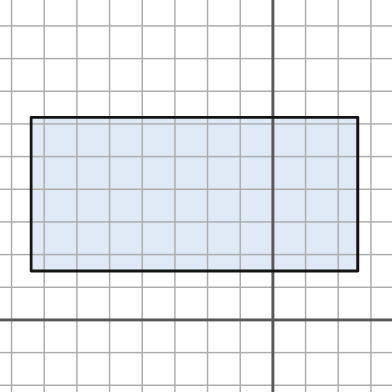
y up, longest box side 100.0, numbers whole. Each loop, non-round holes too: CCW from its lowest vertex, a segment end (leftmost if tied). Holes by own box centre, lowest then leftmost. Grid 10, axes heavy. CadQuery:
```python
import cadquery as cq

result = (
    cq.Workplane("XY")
    .moveTo(-74.0, 15.0)
    .lineTo(26.0, 15.0)
    .lineTo(26.0, 62.0)
    .lineTo(-74.0, 62.0)
    .close()
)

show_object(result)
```